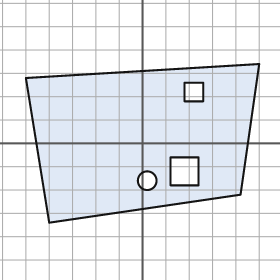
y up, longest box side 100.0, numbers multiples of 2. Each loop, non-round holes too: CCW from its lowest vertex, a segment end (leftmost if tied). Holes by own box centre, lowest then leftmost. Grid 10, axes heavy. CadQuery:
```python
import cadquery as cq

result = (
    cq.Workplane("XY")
    .moveTo(-40.0, -34.0)
    .lineTo(42.0, -22.0)
    .lineTo(50.0, 34.0)
    .lineTo(-50.0, 28.0)
    .close()
    .moveTo(2.0, -16.0)
    .circle(4.0)
    .moveTo(12.0, -18.0)
    .lineTo(24.0, -18.0)
    .lineTo(24.0, -6.0)
    .lineTo(12.0, -6.0)
    .close()
    .moveTo(18.0, 18.0)
    .lineTo(26.0, 18.0)
    .lineTo(26.0, 26.0)
    .lineTo(18.0, 26.0)
    .close()
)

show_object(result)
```